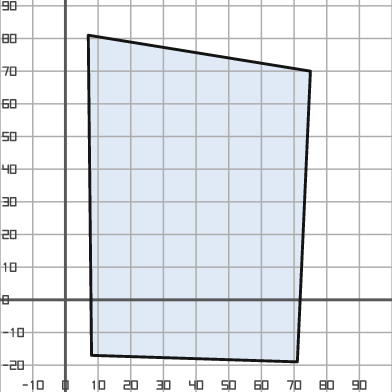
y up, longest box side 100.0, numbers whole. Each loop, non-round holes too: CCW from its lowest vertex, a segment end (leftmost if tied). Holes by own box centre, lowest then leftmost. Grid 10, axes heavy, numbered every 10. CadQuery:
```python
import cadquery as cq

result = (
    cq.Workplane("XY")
    .moveTo(71.0, -19.0)
    .lineTo(75.0, 70.0)
    .lineTo(7.0, 81.0)
    .lineTo(8.0, -17.0)
    .close()
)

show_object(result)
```